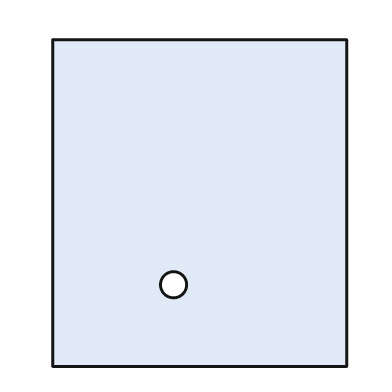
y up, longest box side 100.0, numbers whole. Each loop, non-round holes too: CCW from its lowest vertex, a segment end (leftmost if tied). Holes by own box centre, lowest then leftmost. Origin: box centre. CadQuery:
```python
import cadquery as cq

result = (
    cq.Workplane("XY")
    .moveTo(-45.0, -50.0)
    .lineTo(45.0, -50.0)
    .lineTo(45.0, 50.0)
    .lineTo(-45.0, 50.0)
    .close()
    .moveTo(-8.0, -25.0)
    .circle(4.0)
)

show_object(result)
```